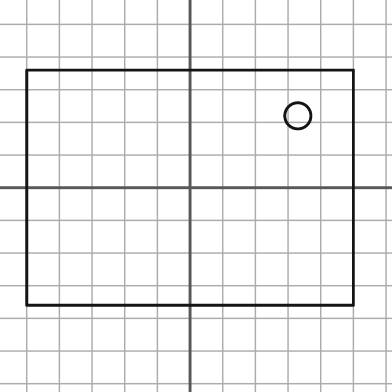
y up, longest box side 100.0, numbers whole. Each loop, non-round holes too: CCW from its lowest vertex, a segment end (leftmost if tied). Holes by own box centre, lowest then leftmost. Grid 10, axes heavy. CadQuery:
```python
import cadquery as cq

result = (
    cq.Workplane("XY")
    .moveTo(-50.0, -36.0)
    .lineTo(50.0, -36.0)
    .lineTo(50.0, 36.0)
    .lineTo(-50.0, 36.0)
    .close()
    .moveTo(33.0, 22.0)
    .circle(4.0)
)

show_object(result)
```